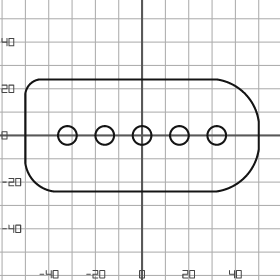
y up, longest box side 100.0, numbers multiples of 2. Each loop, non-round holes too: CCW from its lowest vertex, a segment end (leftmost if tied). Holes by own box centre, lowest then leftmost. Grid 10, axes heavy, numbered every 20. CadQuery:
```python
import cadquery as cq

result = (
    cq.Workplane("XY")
    .moveTo(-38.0, -24.0)
    .lineTo(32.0, -24.0)
    .threePointArc((44.0, -18.0), (50.0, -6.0))
    .lineTo(50.0, 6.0)
    .threePointArc((44.0, 18.0), (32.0, 24.0))
    .lineTo(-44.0, 24.0)
    .threePointArc((-48.0, 22.0), (-50.0, 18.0))
    .lineTo(-50.0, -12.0)
    .threePointArc((-46.0, -20.0), (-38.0, -24.0))
    .close()
    .moveTo(-32.0, 0.0)
    .circle(4.0)
    .moveTo(-16.0, 0.0)
    .circle(4.0)
    .moveTo(0.0, 0.0)
    .circle(4.0)
    .moveTo(16.0, 0.0)
    .circle(4.0)
    .moveTo(32.0, 0.0)
    .circle(4.0)
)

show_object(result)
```